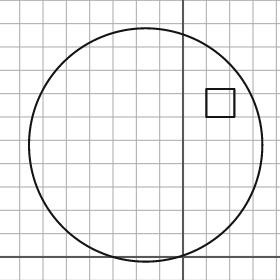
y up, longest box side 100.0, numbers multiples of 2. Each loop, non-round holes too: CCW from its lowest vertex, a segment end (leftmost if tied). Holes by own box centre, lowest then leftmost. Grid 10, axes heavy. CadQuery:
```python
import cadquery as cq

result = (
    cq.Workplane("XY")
    .moveTo(-16.0, 48.0)
    .circle(50.0)
    .moveTo(10.0, 60.0)
    .lineTo(22.0, 60.0)
    .lineTo(22.0, 72.0)
    .lineTo(10.0, 72.0)
    .close()
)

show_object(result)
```